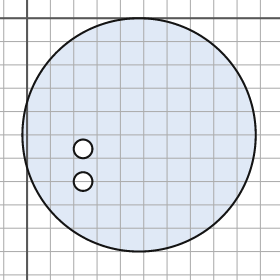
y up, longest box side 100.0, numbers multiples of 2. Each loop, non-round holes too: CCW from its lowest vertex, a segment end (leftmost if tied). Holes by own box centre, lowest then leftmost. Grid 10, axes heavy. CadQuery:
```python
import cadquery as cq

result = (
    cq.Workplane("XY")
    .moveTo(48.0, -50.0)
    .circle(50.0)
    .moveTo(24.0, -70.0)
    .circle(4.0)
    .moveTo(24.0, -56.0)
    .circle(4.0)
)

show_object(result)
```